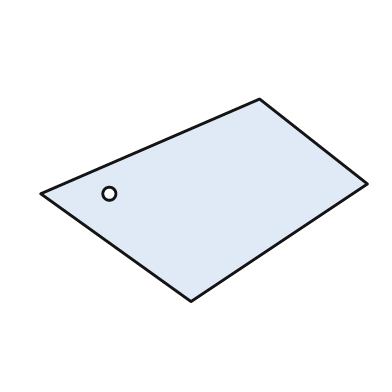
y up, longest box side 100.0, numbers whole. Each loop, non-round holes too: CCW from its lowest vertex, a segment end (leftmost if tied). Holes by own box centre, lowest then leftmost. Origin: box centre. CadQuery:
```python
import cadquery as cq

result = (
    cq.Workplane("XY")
    .moveTo(-4.0, -31.0)
    .lineTo(50.0, 5.0)
    .lineTo(17.0, 31.0)
    .lineTo(-50.0, 2.0)
    .close()
    .moveTo(-29.0, 2.0)
    .circle(2.0)
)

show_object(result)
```